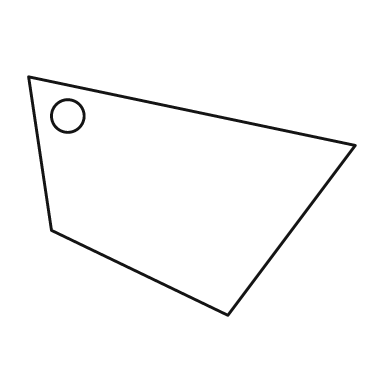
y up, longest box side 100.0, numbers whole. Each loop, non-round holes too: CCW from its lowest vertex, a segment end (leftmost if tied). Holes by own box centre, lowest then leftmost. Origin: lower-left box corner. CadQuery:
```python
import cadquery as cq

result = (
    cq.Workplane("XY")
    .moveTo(61.0, 0.0)
    .lineTo(100.0, 52.0)
    .lineTo(0.0, 73.0)
    .lineTo(7.0, 26.0)
    .close()
    .moveTo(12.0, 61.0)
    .circle(5.0)
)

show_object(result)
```